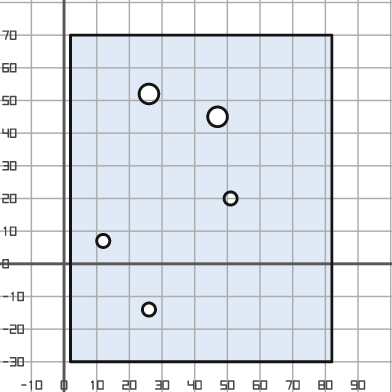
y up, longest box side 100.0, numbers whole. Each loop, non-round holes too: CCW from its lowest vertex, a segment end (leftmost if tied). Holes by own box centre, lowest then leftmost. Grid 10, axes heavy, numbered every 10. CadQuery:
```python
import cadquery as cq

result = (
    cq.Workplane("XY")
    .moveTo(2.0, -30.0)
    .lineTo(82.0, -30.0)
    .lineTo(82.0, 70.0)
    .lineTo(2.0, 70.0)
    .close()
    .moveTo(26.0, -14.0)
    .circle(2.0)
    .moveTo(12.0, 7.0)
    .circle(2.0)
    .moveTo(51.0, 20.0)
    .circle(2.0)
    .moveTo(47.0, 45.0)
    .circle(3.0)
    .moveTo(26.0, 52.0)
    .circle(3.0)
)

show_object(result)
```